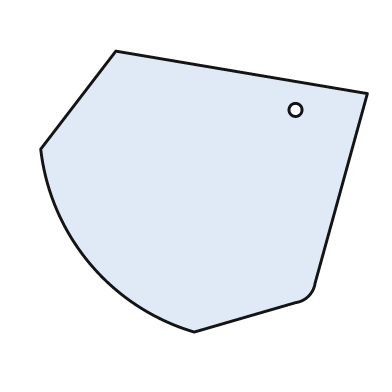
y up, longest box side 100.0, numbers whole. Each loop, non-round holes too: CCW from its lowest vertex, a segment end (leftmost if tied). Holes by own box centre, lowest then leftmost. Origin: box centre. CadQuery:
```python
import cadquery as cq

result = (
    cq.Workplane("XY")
    .moveTo(-3.0, -43.0)
    .lineTo(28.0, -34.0)
    .threePointArc((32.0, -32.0), (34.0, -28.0))
    .lineTo(50.0, 30.0)
    .lineTo(-27.0, 43.0)
    .lineTo(-50.0, 13.0)
    .threePointArc((-35.0, -22.0), (-3.0, -43.0))
    .close()
    .moveTo(28.0, 25.0)
    .circle(2.0)
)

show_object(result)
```